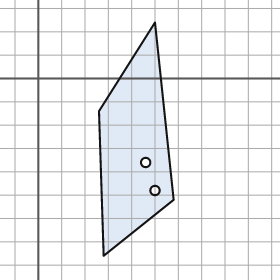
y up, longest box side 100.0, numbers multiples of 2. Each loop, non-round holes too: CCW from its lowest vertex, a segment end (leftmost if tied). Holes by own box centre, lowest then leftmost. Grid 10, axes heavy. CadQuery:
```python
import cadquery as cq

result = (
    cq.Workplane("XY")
    .moveTo(28.0, -76.0)
    .lineTo(58.0, -52.0)
    .lineTo(50.0, 24.0)
    .lineTo(26.0, -14.0)
    .close()
    .moveTo(50.0, -48.0)
    .circle(2.0)
    .moveTo(46.0, -36.0)
    .circle(2.0)
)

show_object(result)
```